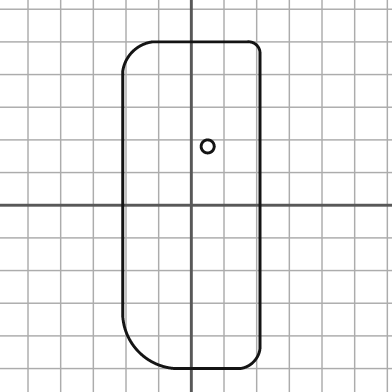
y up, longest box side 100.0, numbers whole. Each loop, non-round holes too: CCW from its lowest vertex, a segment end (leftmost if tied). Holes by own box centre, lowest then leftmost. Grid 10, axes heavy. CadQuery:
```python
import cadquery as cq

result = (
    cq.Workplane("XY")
    .moveTo(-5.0, -50.0)
    .lineTo(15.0, -50.0)
    .threePointArc((19.0, -48.0), (21.0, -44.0))
    .lineTo(21.0, 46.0)
    .threePointArc((20.0, 49.0), (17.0, 50.0))
    .lineTo(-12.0, 50.0)
    .threePointArc((-18.0, 47.0), (-21.0, 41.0))
    .lineTo(-21.0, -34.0)
    .threePointArc((-16.0, -45.0), (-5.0, -50.0))
    .close()
    .moveTo(5.0, 18.0)
    .circle(2.0)
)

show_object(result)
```